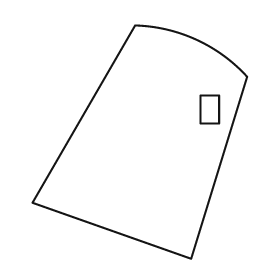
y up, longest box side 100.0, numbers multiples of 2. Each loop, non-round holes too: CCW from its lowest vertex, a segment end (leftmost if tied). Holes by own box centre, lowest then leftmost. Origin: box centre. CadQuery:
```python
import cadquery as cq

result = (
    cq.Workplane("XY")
    .moveTo(22.0, -50.0)
    .lineTo(46.0, 28.0)
    .threePointArc((24.0, 44.0), (-2.0, 50.0))
    .lineTo(-46.0, -26.0)
    .close()
    .moveTo(26.0, 8.0)
    .lineTo(34.0, 8.0)
    .lineTo(34.0, 20.0)
    .lineTo(26.0, 20.0)
    .close()
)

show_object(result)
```